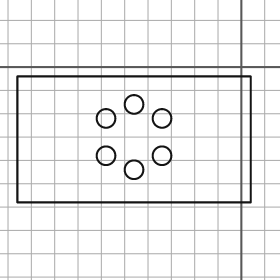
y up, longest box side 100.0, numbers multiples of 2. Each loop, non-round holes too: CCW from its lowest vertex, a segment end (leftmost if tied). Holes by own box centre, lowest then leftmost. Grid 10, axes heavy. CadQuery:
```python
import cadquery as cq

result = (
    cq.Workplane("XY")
    .moveTo(-96.0, -58.0)
    .lineTo(4.0, -58.0)
    .lineTo(4.0, -4.0)
    .lineTo(-96.0, -4.0)
    .close()
    .moveTo(-46.0, -44.0)
    .circle(4.0)
    .moveTo(-58.0, -38.0)
    .circle(4.0)
    .moveTo(-34.0, -38.0)
    .circle(4.0)
    .moveTo(-58.0, -22.0)
    .circle(4.0)
    .moveTo(-34.0, -22.0)
    .circle(4.0)
    .moveTo(-46.0, -16.0)
    .circle(4.0)
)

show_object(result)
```